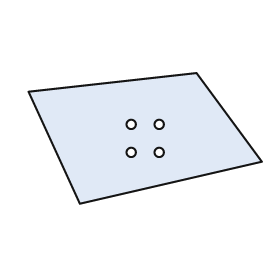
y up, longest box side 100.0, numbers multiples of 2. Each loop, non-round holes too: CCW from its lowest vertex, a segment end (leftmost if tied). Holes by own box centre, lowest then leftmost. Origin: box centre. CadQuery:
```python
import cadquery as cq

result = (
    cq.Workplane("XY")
    .moveTo(-28.0, -28.0)
    .lineTo(50.0, -10.0)
    .lineTo(22.0, 28.0)
    .lineTo(-50.0, 20.0)
    .close()
    .moveTo(-6.0, -6.0)
    .circle(2.0)
    .moveTo(6.0, -6.0)
    .circle(2.0)
    .moveTo(-6.0, 6.0)
    .circle(2.0)
    .moveTo(6.0, 6.0)
    .circle(2.0)
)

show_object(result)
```